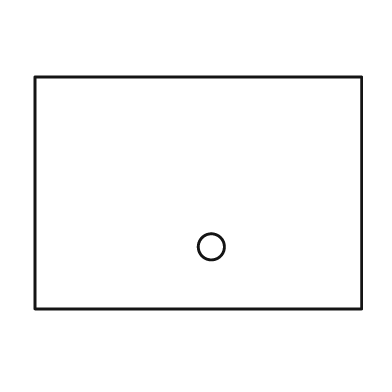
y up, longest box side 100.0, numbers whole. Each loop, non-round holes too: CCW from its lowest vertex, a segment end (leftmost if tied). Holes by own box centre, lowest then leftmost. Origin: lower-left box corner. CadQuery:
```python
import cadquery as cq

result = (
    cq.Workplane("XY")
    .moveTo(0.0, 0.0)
    .lineTo(100.0, 0.0)
    .lineTo(100.0, 71.0)
    .lineTo(0.0, 71.0)
    .close()
    .moveTo(54.0, 19.0)
    .circle(4.0)
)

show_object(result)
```